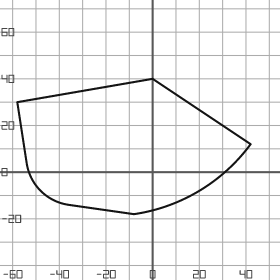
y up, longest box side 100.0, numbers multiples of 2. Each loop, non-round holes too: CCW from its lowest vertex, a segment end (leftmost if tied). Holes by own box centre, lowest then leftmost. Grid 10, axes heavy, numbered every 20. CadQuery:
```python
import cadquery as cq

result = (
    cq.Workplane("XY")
    .moveTo(-8.0, -18.0)
    .threePointArc((20.0, -8.0), (42.0, 12.0))
    .lineTo(0.0, 40.0)
    .lineTo(-58.0, 30.0)
    .lineTo(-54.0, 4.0)
    .threePointArc((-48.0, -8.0), (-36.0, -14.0))
    .close()
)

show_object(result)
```